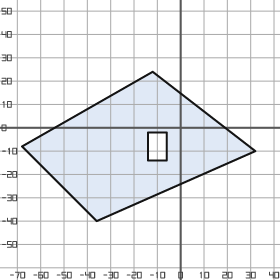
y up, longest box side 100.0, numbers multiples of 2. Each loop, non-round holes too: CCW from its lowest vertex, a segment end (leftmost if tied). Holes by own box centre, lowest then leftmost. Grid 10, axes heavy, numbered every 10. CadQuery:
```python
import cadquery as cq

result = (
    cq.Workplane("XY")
    .moveTo(-36.0, -40.0)
    .lineTo(32.0, -10.0)
    .lineTo(-12.0, 24.0)
    .lineTo(-68.0, -8.0)
    .close()
    .moveTo(-14.0, -14.0)
    .lineTo(-6.0, -14.0)
    .lineTo(-6.0, -2.0)
    .lineTo(-14.0, -2.0)
    .close()
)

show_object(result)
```